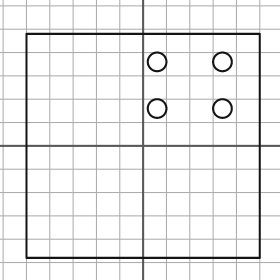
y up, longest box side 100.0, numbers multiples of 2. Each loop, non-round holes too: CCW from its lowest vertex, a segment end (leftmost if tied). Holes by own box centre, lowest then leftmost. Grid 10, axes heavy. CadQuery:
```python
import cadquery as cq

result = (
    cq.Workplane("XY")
    .moveTo(-50.0, -48.0)
    .lineTo(50.0, -48.0)
    .lineTo(50.0, 48.0)
    .lineTo(-50.0, 48.0)
    .close()
    .moveTo(6.0, 16.0)
    .circle(4.0)
    .moveTo(34.0, 16.0)
    .circle(4.0)
    .moveTo(6.0, 36.0)
    .circle(4.0)
    .moveTo(34.0, 36.0)
    .circle(4.0)
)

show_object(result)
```